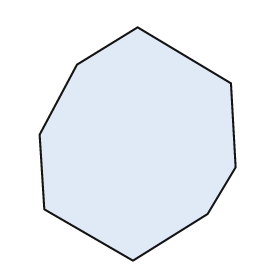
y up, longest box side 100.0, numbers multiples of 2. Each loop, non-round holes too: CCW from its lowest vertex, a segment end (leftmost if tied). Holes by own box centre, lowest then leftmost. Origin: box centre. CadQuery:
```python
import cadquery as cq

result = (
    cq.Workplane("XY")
    .moveTo(-2.0, -50.0)
    .lineTo(30.0, -30.0)
    .lineTo(42.0, -10.0)
    .lineTo(40.0, 26.0)
    .lineTo(0.0, 50.0)
    .lineTo(-26.0, 34.0)
    .lineTo(-42.0, 4.0)
    .lineTo(-40.0, -28.0)
    .close()
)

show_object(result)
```